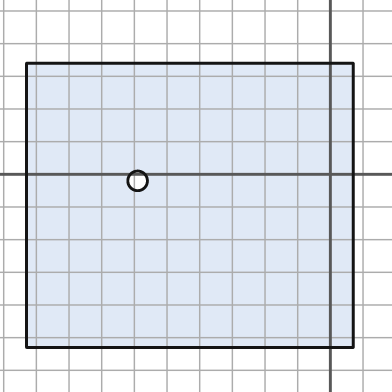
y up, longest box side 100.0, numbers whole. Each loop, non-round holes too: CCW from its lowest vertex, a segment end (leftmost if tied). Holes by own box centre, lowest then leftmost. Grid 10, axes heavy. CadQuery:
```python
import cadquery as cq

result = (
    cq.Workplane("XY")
    .moveTo(-93.0, -53.0)
    .lineTo(7.0, -53.0)
    .lineTo(7.0, 34.0)
    .lineTo(-93.0, 34.0)
    .close()
    .moveTo(-59.0, -2.0)
    .circle(3.0)
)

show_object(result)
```